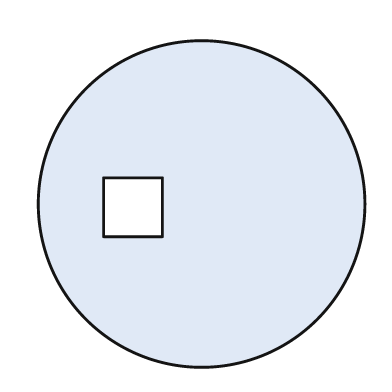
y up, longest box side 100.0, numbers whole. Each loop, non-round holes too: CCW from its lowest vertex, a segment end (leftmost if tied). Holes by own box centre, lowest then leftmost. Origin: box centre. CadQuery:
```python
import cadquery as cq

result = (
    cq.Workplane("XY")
    .moveTo(0.0, 0.0)
    .circle(50.0)
    .moveTo(-30.0, -10.0)
    .lineTo(-12.0, -10.0)
    .lineTo(-12.0, 8.0)
    .lineTo(-30.0, 8.0)
    .close()
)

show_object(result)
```